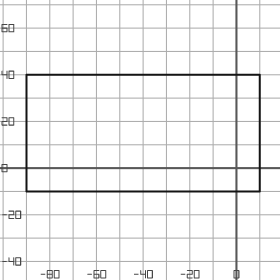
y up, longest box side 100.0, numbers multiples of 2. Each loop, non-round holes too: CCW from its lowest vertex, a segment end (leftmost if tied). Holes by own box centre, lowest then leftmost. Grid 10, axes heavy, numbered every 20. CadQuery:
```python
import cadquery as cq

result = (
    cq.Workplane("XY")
    .moveTo(-90.0, -10.0)
    .lineTo(10.0, -10.0)
    .lineTo(10.0, 40.0)
    .lineTo(-90.0, 40.0)
    .close()
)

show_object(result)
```